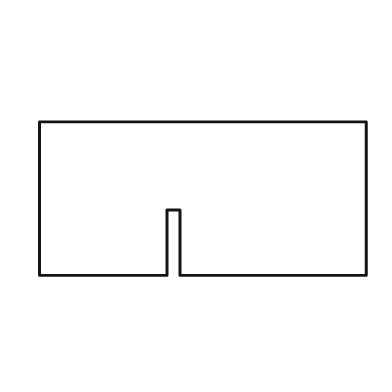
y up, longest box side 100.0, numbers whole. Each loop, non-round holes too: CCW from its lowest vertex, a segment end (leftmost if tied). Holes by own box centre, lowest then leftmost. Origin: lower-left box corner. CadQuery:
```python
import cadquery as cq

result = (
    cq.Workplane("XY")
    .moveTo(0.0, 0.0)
    .lineTo(39.0, 0.0)
    .lineTo(39.0, 20.0)
    .lineTo(43.0, 20.0)
    .lineTo(43.0, 0.0)
    .lineTo(100.0, 0.0)
    .lineTo(100.0, 47.0)
    .lineTo(0.0, 47.0)
    .close()
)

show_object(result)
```